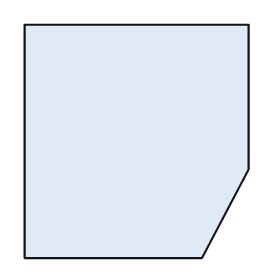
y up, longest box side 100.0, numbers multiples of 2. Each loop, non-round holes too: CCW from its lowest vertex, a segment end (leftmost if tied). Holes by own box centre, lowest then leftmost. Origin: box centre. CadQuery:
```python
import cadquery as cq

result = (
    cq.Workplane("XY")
    .moveTo(-48.0, -50.0)
    .lineTo(28.0, -50.0)
    .lineTo(48.0, -12.0)
    .lineTo(48.0, 50.0)
    .lineTo(-48.0, 50.0)
    .close()
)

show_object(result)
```